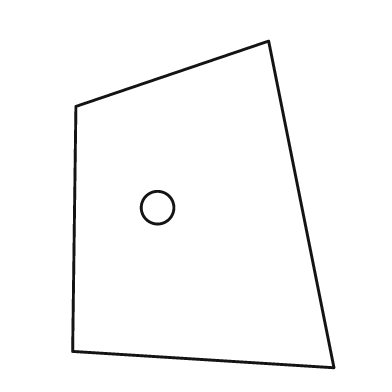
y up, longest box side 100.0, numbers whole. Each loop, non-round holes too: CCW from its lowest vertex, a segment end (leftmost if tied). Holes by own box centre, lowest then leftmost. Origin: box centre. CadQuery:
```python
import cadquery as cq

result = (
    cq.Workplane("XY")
    .moveTo(40.0, -50.0)
    .lineTo(20.0, 50.0)
    .lineTo(-39.0, 30.0)
    .lineTo(-40.0, -45.0)
    .close()
    .moveTo(-14.0, -1.0)
    .circle(5.0)
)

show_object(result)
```